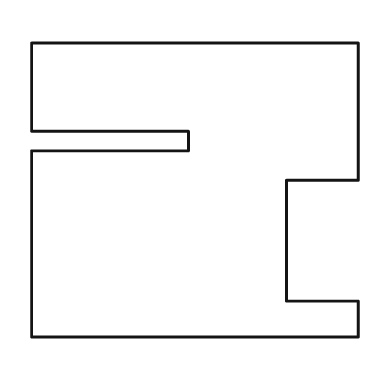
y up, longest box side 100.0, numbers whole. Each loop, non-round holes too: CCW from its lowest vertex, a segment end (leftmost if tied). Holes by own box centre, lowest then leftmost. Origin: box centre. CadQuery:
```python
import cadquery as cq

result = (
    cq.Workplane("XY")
    .moveTo(-50.0, -45.0)
    .lineTo(50.0, -45.0)
    .lineTo(50.0, -34.0)
    .lineTo(28.0, -34.0)
    .lineTo(28.0, 3.0)
    .lineTo(50.0, 3.0)
    .lineTo(50.0, 45.0)
    .lineTo(-50.0, 45.0)
    .lineTo(-50.0, 18.0)
    .lineTo(-2.0, 18.0)
    .lineTo(-2.0, 12.0)
    .lineTo(-50.0, 12.0)
    .close()
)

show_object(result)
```